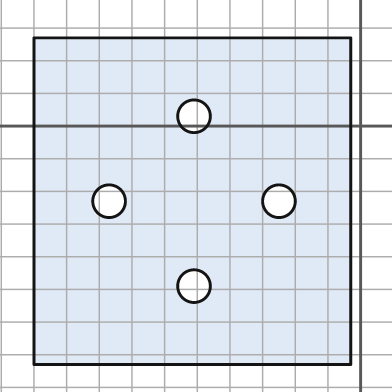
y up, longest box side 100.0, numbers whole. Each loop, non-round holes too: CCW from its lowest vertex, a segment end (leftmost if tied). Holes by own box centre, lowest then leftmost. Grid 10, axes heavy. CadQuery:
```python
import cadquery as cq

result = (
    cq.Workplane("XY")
    .moveTo(-100.0, -73.0)
    .lineTo(-3.0, -73.0)
    .lineTo(-3.0, 27.0)
    .lineTo(-100.0, 27.0)
    .close()
    .moveTo(-51.0, -49.0)
    .circle(5.0)
    .moveTo(-77.0, -23.0)
    .circle(5.0)
    .moveTo(-25.0, -23.0)
    .circle(5.0)
    .moveTo(-51.0, 3.0)
    .circle(5.0)
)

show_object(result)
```